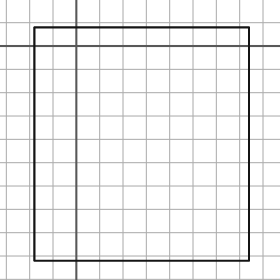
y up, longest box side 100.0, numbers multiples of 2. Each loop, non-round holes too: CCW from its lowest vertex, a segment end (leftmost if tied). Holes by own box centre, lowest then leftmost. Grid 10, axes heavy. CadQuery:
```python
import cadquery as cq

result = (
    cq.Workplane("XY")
    .moveTo(-18.0, -92.0)
    .lineTo(74.0, -92.0)
    .lineTo(74.0, 8.0)
    .lineTo(-18.0, 8.0)
    .close()
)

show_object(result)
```